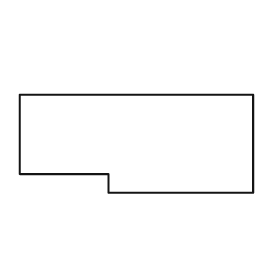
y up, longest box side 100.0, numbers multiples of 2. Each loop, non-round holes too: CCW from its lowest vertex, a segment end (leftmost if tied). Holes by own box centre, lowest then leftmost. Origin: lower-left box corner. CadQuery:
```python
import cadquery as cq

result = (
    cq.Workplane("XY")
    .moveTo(38.0, 0.0)
    .lineTo(100.0, 0.0)
    .lineTo(100.0, 42.0)
    .lineTo(0.0, 42.0)
    .lineTo(0.0, 8.0)
    .lineTo(38.0, 8.0)
    .close()
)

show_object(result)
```